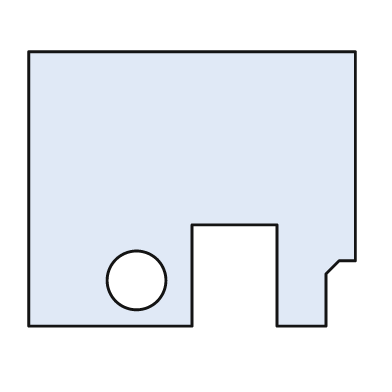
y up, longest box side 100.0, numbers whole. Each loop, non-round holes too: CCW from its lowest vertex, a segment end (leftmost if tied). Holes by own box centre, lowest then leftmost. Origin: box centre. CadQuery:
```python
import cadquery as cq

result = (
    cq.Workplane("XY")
    .moveTo(-50.0, -42.0)
    .lineTo(0.0, -42.0)
    .lineTo(0.0, -11.0)
    .lineTo(26.0, -11.0)
    .lineTo(26.0, -42.0)
    .lineTo(41.0, -42.0)
    .lineTo(41.0, -26.0)
    .lineTo(45.0, -22.0)
    .lineTo(50.0, -22.0)
    .lineTo(50.0, 42.0)
    .lineTo(-50.0, 42.0)
    .close()
    .moveTo(-17.0, -28.0)
    .circle(9.0)
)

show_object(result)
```